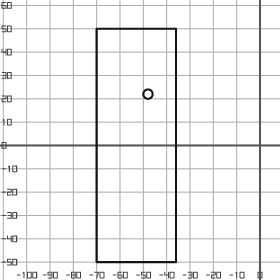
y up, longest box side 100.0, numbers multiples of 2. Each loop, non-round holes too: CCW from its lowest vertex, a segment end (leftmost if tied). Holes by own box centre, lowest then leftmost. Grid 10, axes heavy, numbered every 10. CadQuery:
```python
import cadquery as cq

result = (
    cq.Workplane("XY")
    .moveTo(-70.0, -50.0)
    .lineTo(-36.0, -50.0)
    .lineTo(-36.0, 50.0)
    .lineTo(-70.0, 50.0)
    .close()
    .moveTo(-48.0, 22.0)
    .circle(2.0)
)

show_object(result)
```